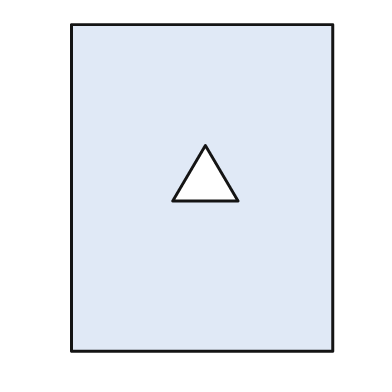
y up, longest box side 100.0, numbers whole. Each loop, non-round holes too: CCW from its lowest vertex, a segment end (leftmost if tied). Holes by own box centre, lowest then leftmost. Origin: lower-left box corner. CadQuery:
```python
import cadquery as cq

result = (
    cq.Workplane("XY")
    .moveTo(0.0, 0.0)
    .lineTo(80.0, 0.0)
    .lineTo(80.0, 100.0)
    .lineTo(0.0, 100.0)
    .close()
    .moveTo(31.0, 46.0)
    .lineTo(51.0, 46.0)
    .lineTo(41.0, 63.0)
    .close()
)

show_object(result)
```